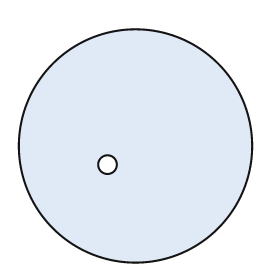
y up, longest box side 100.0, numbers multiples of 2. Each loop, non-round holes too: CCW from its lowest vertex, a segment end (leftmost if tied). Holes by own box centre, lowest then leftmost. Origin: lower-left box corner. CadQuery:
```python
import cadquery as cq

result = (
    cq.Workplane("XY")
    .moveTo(50.0, 50.0)
    .circle(50.0)
    .moveTo(38.0, 42.0)
    .circle(4.0)
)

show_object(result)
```